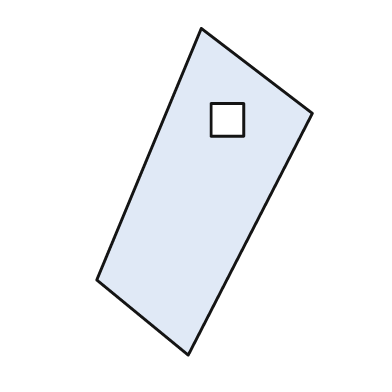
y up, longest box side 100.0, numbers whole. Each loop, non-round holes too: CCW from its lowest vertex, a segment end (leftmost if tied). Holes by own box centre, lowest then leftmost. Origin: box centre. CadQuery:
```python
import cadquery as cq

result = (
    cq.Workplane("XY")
    .moveTo(-5.0, -50.0)
    .lineTo(33.0, 24.0)
    .lineTo(-1.0, 50.0)
    .lineTo(-33.0, -27.0)
    .close()
    .moveTo(2.0, 17.0)
    .lineTo(12.0, 17.0)
    .lineTo(12.0, 27.0)
    .lineTo(2.0, 27.0)
    .close()
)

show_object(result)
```